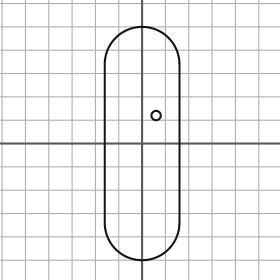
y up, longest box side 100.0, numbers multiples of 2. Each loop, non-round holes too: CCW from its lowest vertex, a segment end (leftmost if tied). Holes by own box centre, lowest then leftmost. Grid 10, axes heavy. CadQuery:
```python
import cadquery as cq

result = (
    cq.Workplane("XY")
    .moveTo(-16.0, -34.0)
    .threePointArc((0.0, -50.0), (16.0, -34.0))
    .lineTo(16.0, 34.0)
    .threePointArc((0.0, 50.0), (-16.0, 34.0))
    .close()
    .moveTo(6.0, 12.0)
    .circle(2.0)
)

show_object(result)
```